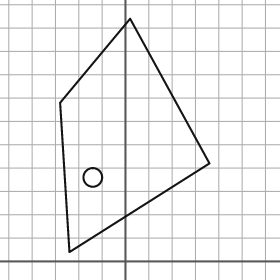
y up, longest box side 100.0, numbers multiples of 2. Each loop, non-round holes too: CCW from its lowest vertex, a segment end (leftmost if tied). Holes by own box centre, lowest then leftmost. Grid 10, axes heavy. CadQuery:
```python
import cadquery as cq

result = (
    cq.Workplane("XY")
    .moveTo(-24.0, 4.0)
    .lineTo(36.0, 42.0)
    .lineTo(2.0, 104.0)
    .lineTo(-28.0, 68.0)
    .close()
    .moveTo(-14.0, 36.0)
    .circle(4.0)
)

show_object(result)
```